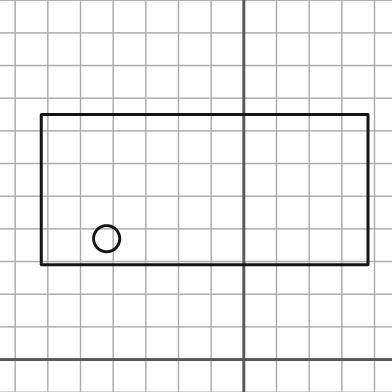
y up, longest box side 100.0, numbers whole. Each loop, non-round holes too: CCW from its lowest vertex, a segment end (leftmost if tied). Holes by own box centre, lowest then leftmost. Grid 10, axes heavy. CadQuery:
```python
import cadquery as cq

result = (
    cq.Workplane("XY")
    .moveTo(-62.0, 29.0)
    .lineTo(38.0, 29.0)
    .lineTo(38.0, 75.0)
    .lineTo(-62.0, 75.0)
    .close()
    .moveTo(-42.0, 37.0)
    .circle(4.0)
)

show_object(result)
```